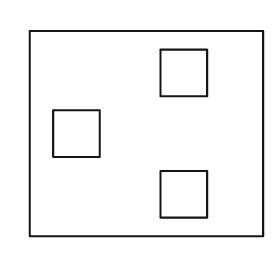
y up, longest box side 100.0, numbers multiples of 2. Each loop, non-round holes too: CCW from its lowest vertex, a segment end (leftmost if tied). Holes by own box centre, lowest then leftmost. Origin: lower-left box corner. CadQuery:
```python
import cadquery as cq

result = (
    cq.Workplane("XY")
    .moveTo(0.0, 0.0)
    .lineTo(100.0, 0.0)
    .lineTo(100.0, 88.0)
    .lineTo(0.0, 88.0)
    .close()
    .moveTo(56.0, 8.0)
    .lineTo(76.0, 8.0)
    .lineTo(76.0, 28.0)
    .lineTo(56.0, 28.0)
    .close()
    .moveTo(10.0, 34.0)
    .lineTo(30.0, 34.0)
    .lineTo(30.0, 54.0)
    .lineTo(10.0, 54.0)
    .close()
    .moveTo(56.0, 60.0)
    .lineTo(76.0, 60.0)
    .lineTo(76.0, 80.0)
    .lineTo(56.0, 80.0)
    .close()
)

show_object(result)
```